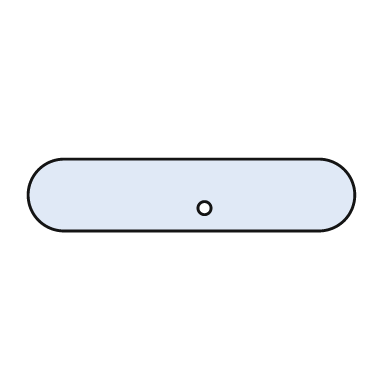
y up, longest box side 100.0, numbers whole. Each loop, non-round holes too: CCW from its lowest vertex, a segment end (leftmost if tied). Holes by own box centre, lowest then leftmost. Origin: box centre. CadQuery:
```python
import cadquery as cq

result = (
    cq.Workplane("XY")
    .moveTo(-39.0, -11.0)
    .lineTo(39.0, -11.0)
    .threePointArc((50.0, 0.0), (39.0, 11.0))
    .lineTo(-39.0, 11.0)
    .threePointArc((-50.0, 0.0), (-39.0, -11.0))
    .close()
    .moveTo(4.0, -4.0)
    .circle(2.0)
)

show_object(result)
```